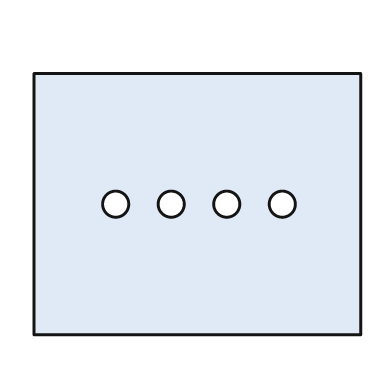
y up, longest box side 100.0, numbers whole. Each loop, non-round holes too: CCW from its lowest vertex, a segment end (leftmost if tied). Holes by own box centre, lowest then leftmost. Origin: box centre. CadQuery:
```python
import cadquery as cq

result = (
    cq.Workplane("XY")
    .moveTo(-50.0, -40.0)
    .lineTo(50.0, -40.0)
    .lineTo(50.0, 40.0)
    .lineTo(-50.0, 40.0)
    .close()
    .moveTo(-25.0, 0.0)
    .circle(4.0)
    .moveTo(-8.0, 0.0)
    .circle(4.0)
    .moveTo(9.0, 0.0)
    .circle(4.0)
    .moveTo(26.0, 0.0)
    .circle(4.0)
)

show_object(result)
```